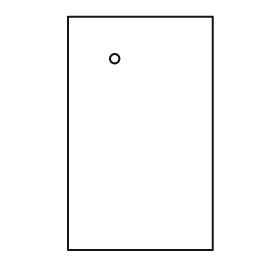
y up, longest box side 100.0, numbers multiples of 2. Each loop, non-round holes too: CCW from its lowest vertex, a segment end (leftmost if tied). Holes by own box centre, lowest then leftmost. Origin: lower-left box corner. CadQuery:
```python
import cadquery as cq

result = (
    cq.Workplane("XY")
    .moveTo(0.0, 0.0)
    .lineTo(62.0, 0.0)
    .lineTo(62.0, 100.0)
    .lineTo(0.0, 100.0)
    .close()
    .moveTo(20.0, 82.0)
    .circle(2.0)
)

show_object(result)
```